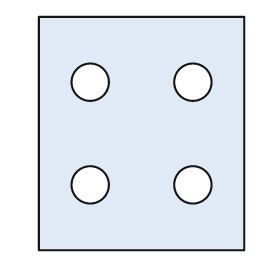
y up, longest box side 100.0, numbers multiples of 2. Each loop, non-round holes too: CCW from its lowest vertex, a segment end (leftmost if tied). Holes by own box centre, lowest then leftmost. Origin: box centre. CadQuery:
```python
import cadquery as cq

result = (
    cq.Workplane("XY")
    .moveTo(-44.0, -50.0)
    .lineTo(44.0, -50.0)
    .lineTo(44.0, 50.0)
    .lineTo(-44.0, 50.0)
    .close()
    .moveTo(-22.0, -22.0)
    .circle(8.0)
    .moveTo(22.0, -22.0)
    .circle(8.0)
    .moveTo(-22.0, 22.0)
    .circle(8.0)
    .moveTo(22.0, 22.0)
    .circle(8.0)
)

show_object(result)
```